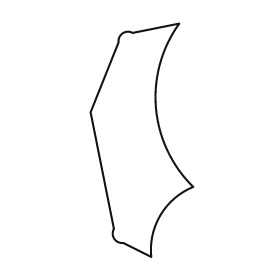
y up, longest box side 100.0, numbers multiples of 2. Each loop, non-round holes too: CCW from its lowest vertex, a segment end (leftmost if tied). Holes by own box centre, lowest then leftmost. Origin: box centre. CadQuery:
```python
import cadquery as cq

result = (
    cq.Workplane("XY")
    .moveTo(4.0, -50.0)
    .threePointArc((8.0, -32.0), (22.0, -20.0))
    .threePointArc((6.0, 14.0), (16.0, 50.0))
    .lineTo(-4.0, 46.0)
    .threePointArc((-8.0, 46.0), (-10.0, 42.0))
    .lineTo(-22.0, 12.0)
    .lineTo(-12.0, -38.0)
    .threePointArc((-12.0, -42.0), (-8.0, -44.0))
    .close()
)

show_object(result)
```